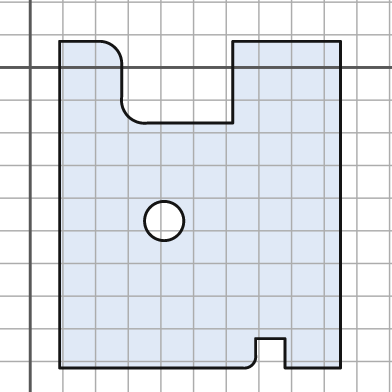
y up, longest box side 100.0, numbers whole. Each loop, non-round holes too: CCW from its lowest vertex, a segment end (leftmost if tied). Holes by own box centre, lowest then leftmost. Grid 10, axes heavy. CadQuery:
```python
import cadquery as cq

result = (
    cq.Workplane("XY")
    .moveTo(9.0, -92.0)
    .lineTo(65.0, -92.0)
    .threePointArc((68.0, -91.0), (69.0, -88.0))
    .lineTo(69.0, -83.0)
    .lineTo(78.0, -83.0)
    .lineTo(78.0, -92.0)
    .lineTo(95.0, -92.0)
    .lineTo(95.0, 8.0)
    .lineTo(62.0, 8.0)
    .lineTo(62.0, -17.0)
    .lineTo(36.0, -17.0)
    .threePointArc((30.0, -15.0), (28.0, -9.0))
    .lineTo(28.0, 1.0)
    .threePointArc((26.0, 6.0), (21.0, 8.0))
    .lineTo(9.0, 8.0)
    .close()
    .moveTo(41.0, -47.0)
    .circle(6.0)
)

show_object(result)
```